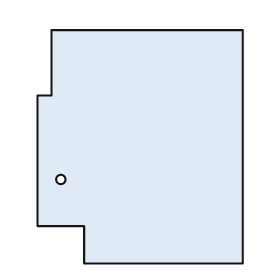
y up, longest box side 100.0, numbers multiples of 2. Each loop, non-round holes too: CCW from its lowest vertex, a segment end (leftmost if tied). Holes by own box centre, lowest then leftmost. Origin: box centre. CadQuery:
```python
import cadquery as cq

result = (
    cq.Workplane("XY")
    .moveTo(-24.0, -50.0)
    .lineTo(44.0, -50.0)
    .lineTo(44.0, 50.0)
    .lineTo(-38.0, 50.0)
    .lineTo(-38.0, 22.0)
    .lineTo(-44.0, 22.0)
    .lineTo(-44.0, -34.0)
    .lineTo(-24.0, -34.0)
    .close()
    .moveTo(-34.0, -14.0)
    .circle(2.0)
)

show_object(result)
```